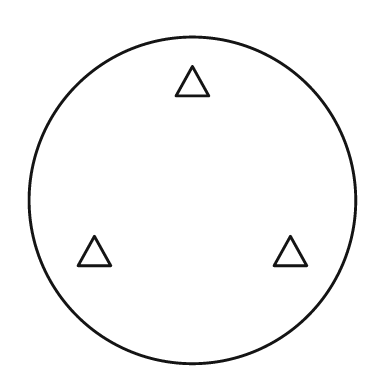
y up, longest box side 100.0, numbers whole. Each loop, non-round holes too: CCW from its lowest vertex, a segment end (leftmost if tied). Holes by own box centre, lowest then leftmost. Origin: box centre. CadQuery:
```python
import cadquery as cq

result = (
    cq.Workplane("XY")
    .moveTo(0.0, 0.0)
    .circle(50.0)
    .moveTo(-35.0, -20.0)
    .lineTo(-25.0, -20.0)
    .lineTo(-30.0, -11.0)
    .close()
    .moveTo(25.0, -20.0)
    .lineTo(35.0, -20.0)
    .lineTo(30.0, -11.0)
    .close()
    .moveTo(-5.0, 32.0)
    .lineTo(5.0, 32.0)
    .lineTo(0.0, 41.0)
    .close()
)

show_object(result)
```